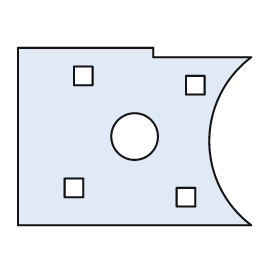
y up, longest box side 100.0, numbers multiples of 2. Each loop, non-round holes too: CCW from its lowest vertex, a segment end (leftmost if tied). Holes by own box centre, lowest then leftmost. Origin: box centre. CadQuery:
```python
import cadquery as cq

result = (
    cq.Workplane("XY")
    .moveTo(-50.0, -38.0)
    .lineTo(50.0, -38.0)
    .threePointArc((32.0, -2.0), (50.0, 34.0))
    .lineTo(8.0, 34.0)
    .lineTo(8.0, 38.0)
    .lineTo(-50.0, 38.0)
    .close()
    .moveTo(18.0, -30.0)
    .lineTo(26.0, -30.0)
    .lineTo(26.0, -22.0)
    .lineTo(18.0, -22.0)
    .close()
    .moveTo(-30.0, -26.0)
    .lineTo(-22.0, -26.0)
    .lineTo(-22.0, -18.0)
    .lineTo(-30.0, -18.0)
    .close()
    .moveTo(0.0, 0.0)
    .circle(10.0)
    .moveTo(22.0, 18.0)
    .lineTo(30.0, 18.0)
    .lineTo(30.0, 26.0)
    .lineTo(22.0, 26.0)
    .close()
    .moveTo(-26.0, 22.0)
    .lineTo(-18.0, 22.0)
    .lineTo(-18.0, 30.0)
    .lineTo(-26.0, 30.0)
    .close()
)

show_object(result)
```